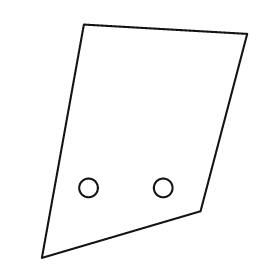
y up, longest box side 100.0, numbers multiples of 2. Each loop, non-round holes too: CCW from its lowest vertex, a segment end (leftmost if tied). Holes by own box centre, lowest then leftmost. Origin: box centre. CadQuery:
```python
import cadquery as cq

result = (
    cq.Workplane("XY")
    .moveTo(-44.0, -50.0)
    .lineTo(24.0, -30.0)
    .lineTo(44.0, 46.0)
    .lineTo(-26.0, 50.0)
    .close()
    .moveTo(-24.0, -20.0)
    .circle(4.0)
    .moveTo(8.0, -20.0)
    .circle(4.0)
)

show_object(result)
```